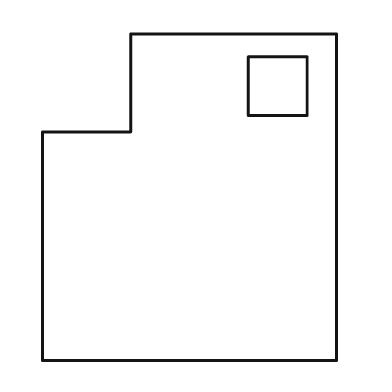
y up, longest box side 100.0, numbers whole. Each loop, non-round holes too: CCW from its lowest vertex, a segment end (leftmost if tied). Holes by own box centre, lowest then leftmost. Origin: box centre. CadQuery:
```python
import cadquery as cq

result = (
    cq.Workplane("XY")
    .moveTo(-45.0, -50.0)
    .lineTo(45.0, -50.0)
    .lineTo(45.0, 50.0)
    .lineTo(-18.0, 50.0)
    .lineTo(-18.0, 20.0)
    .lineTo(-45.0, 20.0)
    .close()
    .moveTo(18.0, 25.0)
    .lineTo(36.0, 25.0)
    .lineTo(36.0, 43.0)
    .lineTo(18.0, 43.0)
    .close()
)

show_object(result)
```